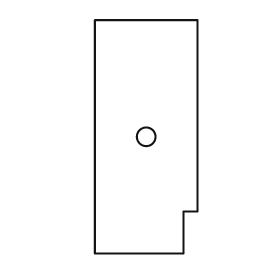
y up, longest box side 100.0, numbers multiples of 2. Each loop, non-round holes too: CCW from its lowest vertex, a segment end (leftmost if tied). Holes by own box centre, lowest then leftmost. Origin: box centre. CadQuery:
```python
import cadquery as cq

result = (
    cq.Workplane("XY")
    .moveTo(-22.0, -50.0)
    .lineTo(16.0, -50.0)
    .lineTo(16.0, -32.0)
    .lineTo(22.0, -32.0)
    .lineTo(22.0, 50.0)
    .lineTo(-22.0, 50.0)
    .close()
    .moveTo(0.0, 0.0)
    .circle(4.0)
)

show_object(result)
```